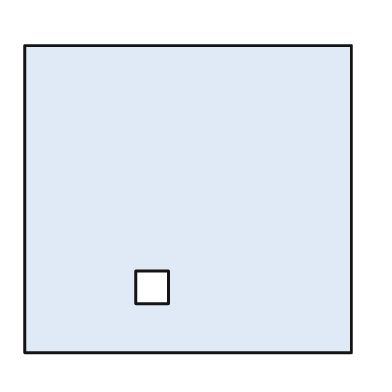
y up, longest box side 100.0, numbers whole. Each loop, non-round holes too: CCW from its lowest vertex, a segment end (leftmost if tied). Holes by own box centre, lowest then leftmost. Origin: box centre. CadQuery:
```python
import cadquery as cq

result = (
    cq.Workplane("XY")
    .moveTo(-50.0, -47.0)
    .lineTo(50.0, -47.0)
    .lineTo(50.0, 47.0)
    .lineTo(-50.0, 47.0)
    .close()
    .moveTo(-16.0, -32.0)
    .lineTo(-6.0, -32.0)
    .lineTo(-6.0, -22.0)
    .lineTo(-16.0, -22.0)
    .close()
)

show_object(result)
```